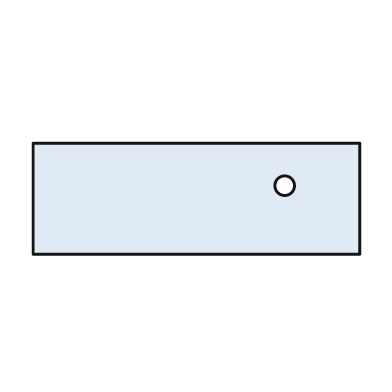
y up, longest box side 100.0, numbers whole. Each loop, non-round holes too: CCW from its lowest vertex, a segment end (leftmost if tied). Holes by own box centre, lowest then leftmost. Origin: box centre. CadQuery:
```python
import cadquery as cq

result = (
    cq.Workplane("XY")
    .moveTo(-50.0, -17.0)
    .lineTo(50.0, -17.0)
    .lineTo(50.0, 17.0)
    .lineTo(-50.0, 17.0)
    .close()
    .moveTo(27.0, 4.0)
    .circle(3.0)
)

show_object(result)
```